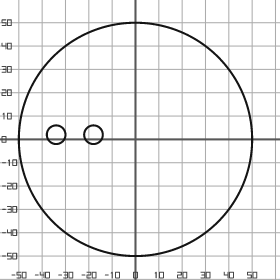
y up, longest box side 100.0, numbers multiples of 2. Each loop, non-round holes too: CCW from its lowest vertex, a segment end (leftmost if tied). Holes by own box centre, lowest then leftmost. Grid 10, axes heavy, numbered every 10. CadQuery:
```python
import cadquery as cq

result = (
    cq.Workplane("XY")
    .moveTo(0.0, 0.0)
    .circle(50.0)
    .moveTo(-34.0, 2.0)
    .circle(4.0)
    .moveTo(-18.0, 2.0)
    .circle(4.0)
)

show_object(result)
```